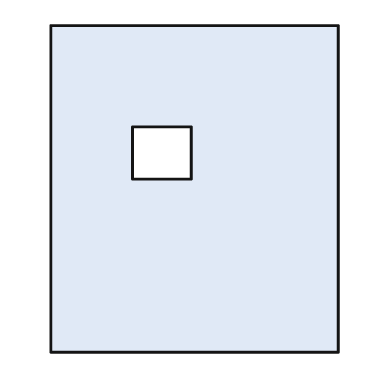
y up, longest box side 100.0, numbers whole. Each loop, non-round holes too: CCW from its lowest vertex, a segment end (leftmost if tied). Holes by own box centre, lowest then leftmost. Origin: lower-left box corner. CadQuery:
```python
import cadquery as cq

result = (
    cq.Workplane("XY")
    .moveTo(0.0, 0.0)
    .lineTo(88.0, 0.0)
    .lineTo(88.0, 100.0)
    .lineTo(0.0, 100.0)
    .close()
    .moveTo(25.0, 53.0)
    .lineTo(43.0, 53.0)
    .lineTo(43.0, 69.0)
    .lineTo(25.0, 69.0)
    .close()
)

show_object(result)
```